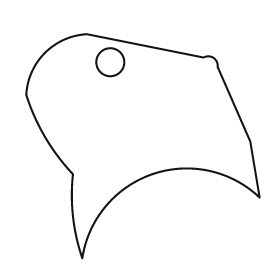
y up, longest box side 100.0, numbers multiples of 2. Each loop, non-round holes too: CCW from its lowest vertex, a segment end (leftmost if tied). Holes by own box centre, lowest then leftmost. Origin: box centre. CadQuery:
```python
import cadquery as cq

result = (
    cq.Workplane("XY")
    .moveTo(-26.0, -48.0)
    .threePointArc((4.0, -12.0), (50.0, -22.0))
    .lineTo(46.0, 2.0)
    .lineTo(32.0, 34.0)
    .threePointArc((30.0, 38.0), (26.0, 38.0))
    .lineTo(-24.0, 48.0)
    .threePointArc((-42.0, 40.0), (-50.0, 22.0))
    .threePointArc((-42.0, 4.0), (-30.0, -12.0))
    .threePointArc((-30.0, -30.0), (-26.0, -48.0))
    .close()
    .moveTo(-14.0, 36.0)
    .circle(6.0)
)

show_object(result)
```